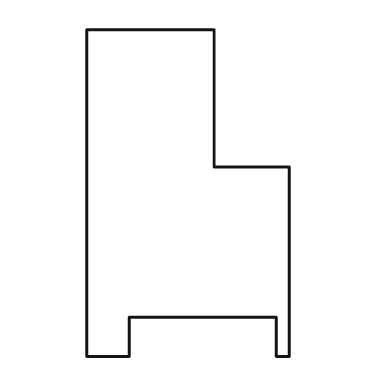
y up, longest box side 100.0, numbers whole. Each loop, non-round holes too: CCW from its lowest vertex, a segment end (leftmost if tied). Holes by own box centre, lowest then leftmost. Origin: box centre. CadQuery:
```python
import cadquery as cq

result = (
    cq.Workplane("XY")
    .moveTo(-31.0, -50.0)
    .lineTo(-18.0, -50.0)
    .lineTo(-18.0, -38.0)
    .lineTo(27.0, -38.0)
    .lineTo(27.0, -50.0)
    .lineTo(31.0, -50.0)
    .lineTo(31.0, 8.0)
    .lineTo(8.0, 8.0)
    .lineTo(8.0, 50.0)
    .lineTo(-31.0, 50.0)
    .close()
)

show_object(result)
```